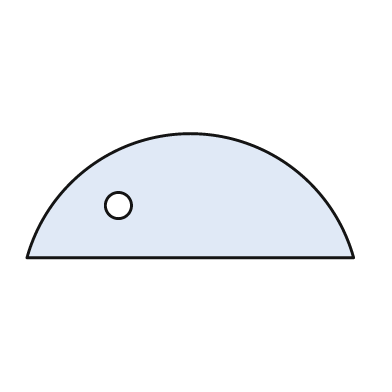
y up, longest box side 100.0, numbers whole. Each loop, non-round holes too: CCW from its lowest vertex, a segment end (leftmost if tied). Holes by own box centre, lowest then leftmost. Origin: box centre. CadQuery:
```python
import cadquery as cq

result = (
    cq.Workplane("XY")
    .moveTo(-50.0, -19.0)
    .lineTo(50.0, -19.0)
    .threePointArc((0.0, 19.0), (-50.0, -19.0))
    .close()
    .moveTo(-22.0, -3.0)
    .circle(4.0)
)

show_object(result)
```